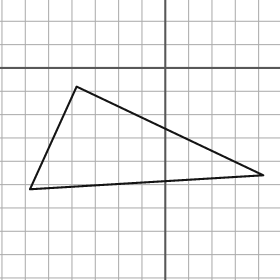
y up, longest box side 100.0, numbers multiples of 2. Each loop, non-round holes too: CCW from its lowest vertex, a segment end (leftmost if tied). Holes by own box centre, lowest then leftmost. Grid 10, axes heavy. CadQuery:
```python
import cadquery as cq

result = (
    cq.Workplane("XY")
    .moveTo(-58.0, -52.0)
    .lineTo(42.0, -46.0)
    .lineTo(-38.0, -8.0)
    .close()
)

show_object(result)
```